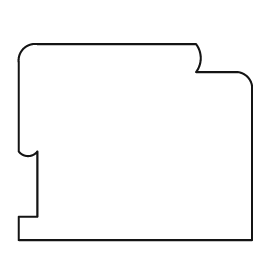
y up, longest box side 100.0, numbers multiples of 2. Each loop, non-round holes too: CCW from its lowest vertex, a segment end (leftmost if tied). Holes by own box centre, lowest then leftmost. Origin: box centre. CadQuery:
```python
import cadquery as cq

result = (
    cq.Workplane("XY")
    .moveTo(-50.0, -42.0)
    .lineTo(50.0, -42.0)
    .lineTo(50.0, 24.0)
    .threePointArc((48.0, 28.0), (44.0, 30.0))
    .lineTo(26.0, 30.0)
    .threePointArc((28.0, 36.0), (26.0, 42.0))
    .lineTo(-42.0, 42.0)
    .threePointArc((-48.0, 40.0), (-50.0, 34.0))
    .lineTo(-50.0, -4.0)
    .threePointArc((-46.0, -6.0), (-42.0, -4.0))
    .lineTo(-42.0, -32.0)
    .lineTo(-50.0, -32.0)
    .close()
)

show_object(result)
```